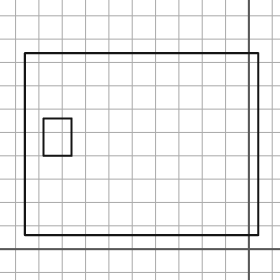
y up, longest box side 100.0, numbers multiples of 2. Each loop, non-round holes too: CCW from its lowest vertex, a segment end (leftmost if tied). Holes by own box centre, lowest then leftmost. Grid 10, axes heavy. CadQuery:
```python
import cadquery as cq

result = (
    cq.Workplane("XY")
    .moveTo(-96.0, 6.0)
    .lineTo(4.0, 6.0)
    .lineTo(4.0, 84.0)
    .lineTo(-96.0, 84.0)
    .close()
    .moveTo(-88.0, 40.0)
    .lineTo(-76.0, 40.0)
    .lineTo(-76.0, 56.0)
    .lineTo(-88.0, 56.0)
    .close()
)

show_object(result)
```